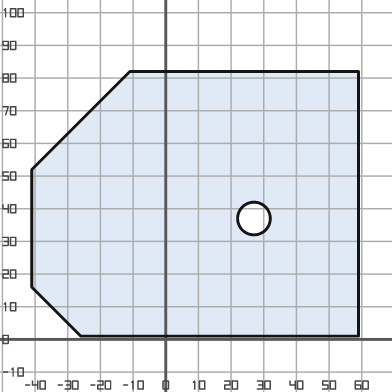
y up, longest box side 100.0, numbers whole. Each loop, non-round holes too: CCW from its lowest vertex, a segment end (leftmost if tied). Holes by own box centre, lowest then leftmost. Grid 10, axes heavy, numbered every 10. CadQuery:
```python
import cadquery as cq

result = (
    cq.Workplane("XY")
    .moveTo(-26.0, 1.0)
    .lineTo(59.0, 1.0)
    .lineTo(59.0, 82.0)
    .lineTo(-11.0, 82.0)
    .lineTo(-41.0, 52.0)
    .lineTo(-41.0, 16.0)
    .close()
    .moveTo(27.0, 37.0)
    .circle(5.0)
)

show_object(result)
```